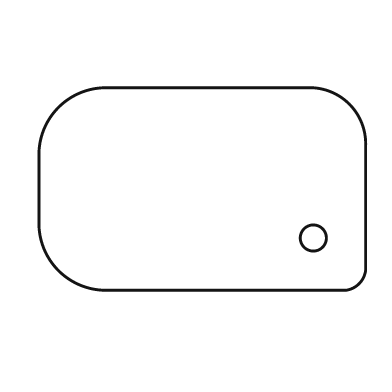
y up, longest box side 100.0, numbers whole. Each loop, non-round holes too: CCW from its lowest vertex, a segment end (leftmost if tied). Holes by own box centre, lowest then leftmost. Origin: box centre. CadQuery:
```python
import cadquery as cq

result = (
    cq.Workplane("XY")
    .moveTo(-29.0, -31.0)
    .lineTo(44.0, -31.0)
    .threePointArc((48.0, -29.0), (50.0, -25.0))
    .lineTo(50.0, 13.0)
    .threePointArc((45.0, 26.0), (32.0, 31.0))
    .lineTo(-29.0, 31.0)
    .threePointArc((-44.0, 25.0), (-50.0, 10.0))
    .lineTo(-50.0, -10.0)
    .threePointArc((-44.0, -25.0), (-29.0, -31.0))
    .close()
    .moveTo(34.0, -15.0)
    .circle(4.0)
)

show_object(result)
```